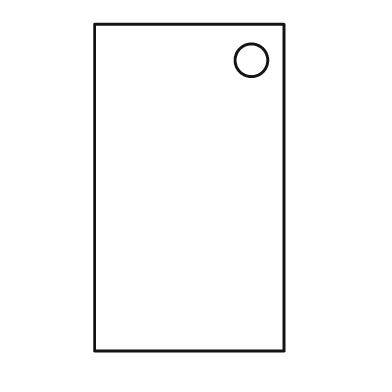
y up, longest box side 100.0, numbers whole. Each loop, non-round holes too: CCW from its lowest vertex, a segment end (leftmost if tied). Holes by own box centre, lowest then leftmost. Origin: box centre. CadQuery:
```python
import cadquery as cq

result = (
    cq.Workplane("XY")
    .moveTo(-29.0, -50.0)
    .lineTo(29.0, -50.0)
    .lineTo(29.0, 50.0)
    .lineTo(-29.0, 50.0)
    .close()
    .moveTo(19.0, 39.0)
    .circle(5.0)
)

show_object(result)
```